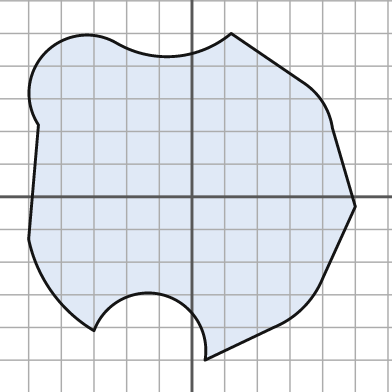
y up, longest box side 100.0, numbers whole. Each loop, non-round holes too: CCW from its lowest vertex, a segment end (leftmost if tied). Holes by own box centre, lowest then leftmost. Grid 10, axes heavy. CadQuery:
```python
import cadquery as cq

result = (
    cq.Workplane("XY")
    .moveTo(4.0, -50.0)
    .lineTo(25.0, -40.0)
    .threePointArc((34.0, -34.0), (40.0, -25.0))
    .lineTo(50.0, -3.0)
    .lineTo(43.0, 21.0)
    .threePointArc((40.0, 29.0), (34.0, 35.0))
    .lineTo(12.0, 50.0)
    .threePointArc((-5.0, 43.0), (-23.0, 47.0))
    .threePointArc((-45.0, 44.0), (-47.0, 22.0))
    .lineTo(-50.0, -13.0)
    .threePointArc((-43.0, -29.0), (-30.0, -41.0))
    .threePointArc((-9.0, -30.0), (4.0, -50.0))
    .close()
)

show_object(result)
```